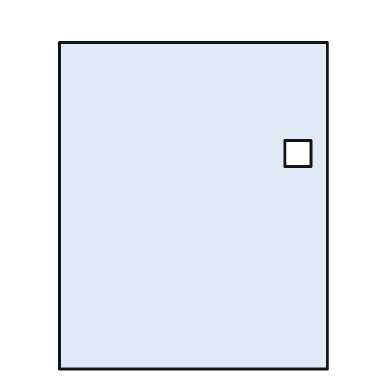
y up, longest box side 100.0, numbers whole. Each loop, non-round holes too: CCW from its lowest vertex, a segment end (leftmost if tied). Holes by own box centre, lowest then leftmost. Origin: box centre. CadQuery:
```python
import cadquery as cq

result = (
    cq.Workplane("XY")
    .moveTo(-41.0, -50.0)
    .lineTo(41.0, -50.0)
    .lineTo(41.0, 50.0)
    .lineTo(-41.0, 50.0)
    .close()
    .moveTo(28.0, 12.0)
    .lineTo(36.0, 12.0)
    .lineTo(36.0, 20.0)
    .lineTo(28.0, 20.0)
    .close()
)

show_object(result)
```